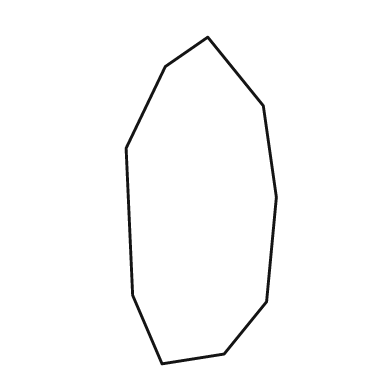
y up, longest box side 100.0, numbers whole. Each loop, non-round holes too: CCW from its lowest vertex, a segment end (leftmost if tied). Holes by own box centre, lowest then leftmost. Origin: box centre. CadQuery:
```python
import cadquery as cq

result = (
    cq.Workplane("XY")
    .moveTo(-12.0, -50.0)
    .lineTo(7.0, -47.0)
    .lineTo(20.0, -31.0)
    .lineTo(23.0, 1.0)
    .lineTo(19.0, 29.0)
    .lineTo(2.0, 50.0)
    .lineTo(-11.0, 41.0)
    .lineTo(-23.0, 16.0)
    .lineTo(-21.0, -29.0)
    .close()
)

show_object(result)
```